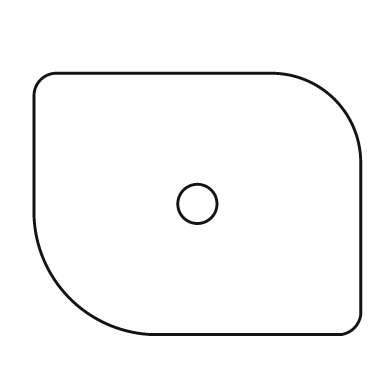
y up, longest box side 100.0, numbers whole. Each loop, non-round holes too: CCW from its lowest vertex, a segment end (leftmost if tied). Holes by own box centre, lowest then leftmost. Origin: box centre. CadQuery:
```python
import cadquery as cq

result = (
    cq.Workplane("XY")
    .moveTo(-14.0, -40.0)
    .lineTo(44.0, -40.0)
    .threePointArc((48.0, -38.0), (50.0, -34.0))
    .lineTo(50.0, 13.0)
    .threePointArc((42.0, 32.0), (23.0, 40.0))
    .lineTo(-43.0, 40.0)
    .threePointArc((-48.0, 38.0), (-50.0, 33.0))
    .lineTo(-50.0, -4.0)
    .threePointArc((-39.0, -29.0), (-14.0, -40.0))
    .close()
    .moveTo(0.0, 0.0)
    .circle(6.0)
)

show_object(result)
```